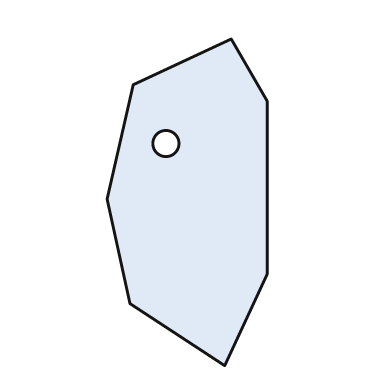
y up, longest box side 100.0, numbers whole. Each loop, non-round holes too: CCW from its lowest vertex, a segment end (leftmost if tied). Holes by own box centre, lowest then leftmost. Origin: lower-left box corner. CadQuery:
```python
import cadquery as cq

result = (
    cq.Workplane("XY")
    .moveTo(36.0, 0.0)
    .lineTo(49.0, 28.0)
    .lineTo(49.0, 81.0)
    .lineTo(38.0, 100.0)
    .lineTo(8.0, 86.0)
    .lineTo(0.0, 51.0)
    .lineTo(7.0, 19.0)
    .close()
    .moveTo(18.0, 68.0)
    .circle(4.0)
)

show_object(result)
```